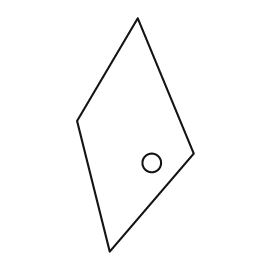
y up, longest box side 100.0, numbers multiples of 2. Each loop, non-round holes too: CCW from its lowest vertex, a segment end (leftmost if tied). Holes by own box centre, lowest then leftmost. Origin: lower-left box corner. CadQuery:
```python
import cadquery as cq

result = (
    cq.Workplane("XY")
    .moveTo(14.0, 0.0)
    .lineTo(50.0, 42.0)
    .lineTo(26.0, 100.0)
    .lineTo(0.0, 56.0)
    .close()
    .moveTo(32.0, 38.0)
    .circle(4.0)
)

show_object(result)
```